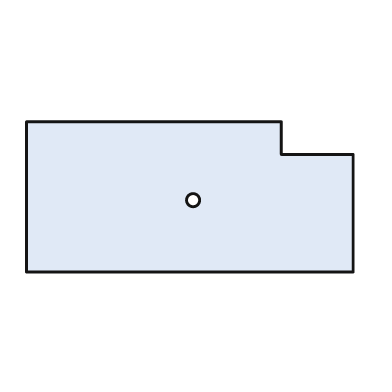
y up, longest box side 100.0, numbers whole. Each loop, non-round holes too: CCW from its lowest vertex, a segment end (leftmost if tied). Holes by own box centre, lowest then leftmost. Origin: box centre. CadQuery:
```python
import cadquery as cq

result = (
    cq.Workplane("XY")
    .moveTo(-50.0, -23.0)
    .lineTo(50.0, -23.0)
    .lineTo(50.0, 13.0)
    .lineTo(28.0, 13.0)
    .lineTo(28.0, 23.0)
    .lineTo(-50.0, 23.0)
    .close()
    .moveTo(1.0, -1.0)
    .circle(2.0)
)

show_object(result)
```